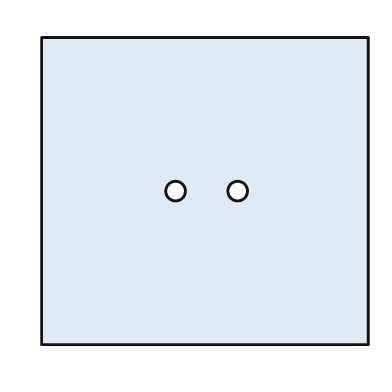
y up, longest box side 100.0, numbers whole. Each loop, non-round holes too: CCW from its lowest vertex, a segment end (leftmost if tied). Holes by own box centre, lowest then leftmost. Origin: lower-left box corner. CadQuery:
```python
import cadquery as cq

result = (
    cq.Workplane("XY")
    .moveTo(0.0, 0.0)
    .lineTo(100.0, 0.0)
    .lineTo(100.0, 94.0)
    .lineTo(0.0, 94.0)
    .close()
    .moveTo(41.0, 47.0)
    .circle(3.0)
    .moveTo(60.0, 47.0)
    .circle(3.0)
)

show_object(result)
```